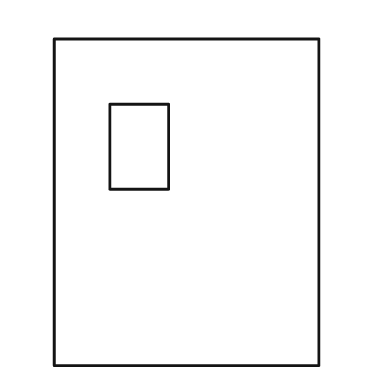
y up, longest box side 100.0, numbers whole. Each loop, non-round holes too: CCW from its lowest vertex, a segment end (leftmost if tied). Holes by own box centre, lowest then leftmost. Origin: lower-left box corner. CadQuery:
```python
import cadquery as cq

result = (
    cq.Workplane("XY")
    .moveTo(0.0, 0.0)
    .lineTo(81.0, 0.0)
    .lineTo(81.0, 100.0)
    .lineTo(0.0, 100.0)
    .close()
    .moveTo(17.0, 54.0)
    .lineTo(35.0, 54.0)
    .lineTo(35.0, 80.0)
    .lineTo(17.0, 80.0)
    .close()
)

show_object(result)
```